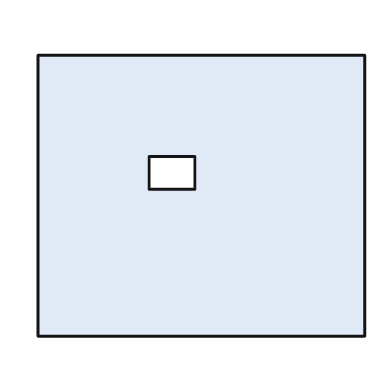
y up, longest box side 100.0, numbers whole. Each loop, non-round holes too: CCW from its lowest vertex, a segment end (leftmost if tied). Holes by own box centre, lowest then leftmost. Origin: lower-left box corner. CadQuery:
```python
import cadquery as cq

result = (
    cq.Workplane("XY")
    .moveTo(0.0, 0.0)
    .lineTo(100.0, 0.0)
    .lineTo(100.0, 86.0)
    .lineTo(0.0, 86.0)
    .close()
    .moveTo(34.0, 45.0)
    .lineTo(48.0, 45.0)
    .lineTo(48.0, 55.0)
    .lineTo(34.0, 55.0)
    .close()
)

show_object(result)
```